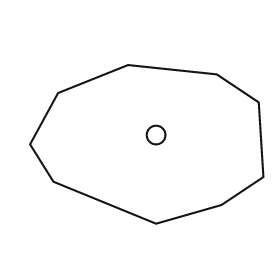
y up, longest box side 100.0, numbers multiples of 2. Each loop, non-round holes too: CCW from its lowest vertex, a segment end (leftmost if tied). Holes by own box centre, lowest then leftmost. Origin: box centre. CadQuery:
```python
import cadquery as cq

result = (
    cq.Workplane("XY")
    .moveTo(4.0, -34.0)
    .lineTo(32.0, -26.0)
    .lineTo(50.0, -14.0)
    .lineTo(48.0, 18.0)
    .lineTo(30.0, 30.0)
    .lineTo(-8.0, 34.0)
    .lineTo(-38.0, 22.0)
    .lineTo(-50.0, 0.0)
    .lineTo(-40.0, -16.0)
    .close()
    .moveTo(4.0, 4.0)
    .circle(4.0)
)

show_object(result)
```